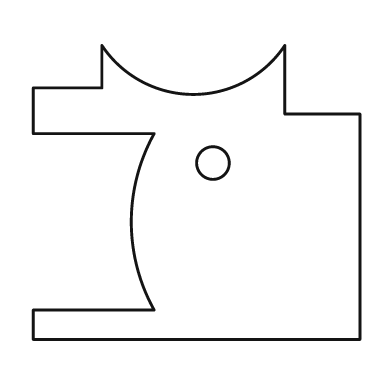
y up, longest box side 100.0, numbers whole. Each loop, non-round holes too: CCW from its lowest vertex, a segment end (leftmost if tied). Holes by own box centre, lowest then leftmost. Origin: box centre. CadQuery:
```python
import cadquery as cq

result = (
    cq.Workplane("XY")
    .moveTo(-50.0, -45.0)
    .lineTo(50.0, -45.0)
    .lineTo(50.0, 24.0)
    .lineTo(27.0, 24.0)
    .lineTo(27.0, 45.0)
    .threePointArc((-1.0, 30.0), (-29.0, 45.0))
    .lineTo(-29.0, 32.0)
    .lineTo(-50.0, 32.0)
    .lineTo(-50.0, 18.0)
    .lineTo(-13.0, 18.0)
    .threePointArc((-20.0, -9.0), (-13.0, -36.0))
    .lineTo(-50.0, -36.0)
    .close()
    .moveTo(5.0, 9.0)
    .circle(5.0)
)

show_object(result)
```